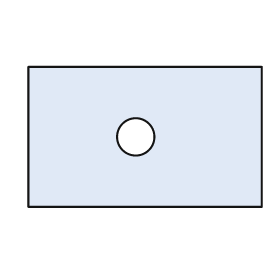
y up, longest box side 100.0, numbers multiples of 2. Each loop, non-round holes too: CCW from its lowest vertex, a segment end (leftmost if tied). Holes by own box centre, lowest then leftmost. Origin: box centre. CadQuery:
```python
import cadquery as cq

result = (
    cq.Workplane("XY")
    .moveTo(-50.0, -30.0)
    .lineTo(50.0, -30.0)
    .lineTo(50.0, 30.0)
    .lineTo(-50.0, 30.0)
    .close()
    .moveTo(-4.0, 0.0)
    .circle(8.0)
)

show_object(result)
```